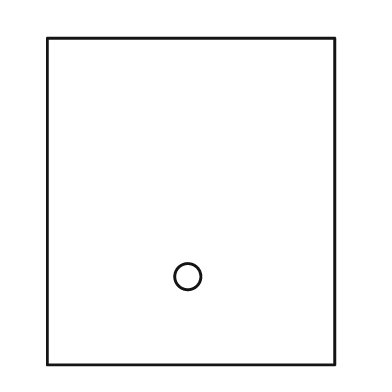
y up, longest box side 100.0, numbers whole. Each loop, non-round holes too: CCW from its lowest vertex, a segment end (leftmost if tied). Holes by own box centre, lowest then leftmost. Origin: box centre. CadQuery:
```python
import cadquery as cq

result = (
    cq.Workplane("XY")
    .moveTo(-44.0, -50.0)
    .lineTo(44.0, -50.0)
    .lineTo(44.0, 50.0)
    .lineTo(-44.0, 50.0)
    .close()
    .moveTo(-1.0, -23.0)
    .circle(4.0)
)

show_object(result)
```